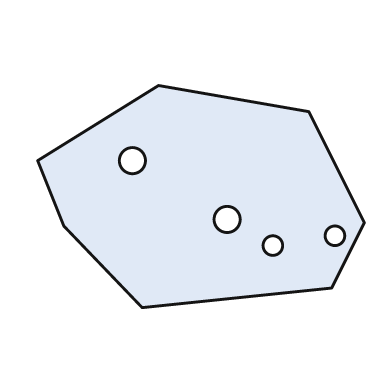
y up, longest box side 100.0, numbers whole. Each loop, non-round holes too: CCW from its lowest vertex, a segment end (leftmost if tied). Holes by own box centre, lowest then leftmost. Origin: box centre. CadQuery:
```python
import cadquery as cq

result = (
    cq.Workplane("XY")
    .moveTo(-18.0, -34.0)
    .lineTo(40.0, -28.0)
    .lineTo(50.0, -8.0)
    .lineTo(33.0, 26.0)
    .lineTo(-13.0, 34.0)
    .lineTo(-50.0, 11.0)
    .lineTo(-42.0, -9.0)
    .close()
    .moveTo(22.0, -15.0)
    .circle(3.0)
    .moveTo(41.0, -12.0)
    .circle(3.0)
    .moveTo(8.0, -7.0)
    .circle(4.0)
    .moveTo(-21.0, 11.0)
    .circle(4.0)
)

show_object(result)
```